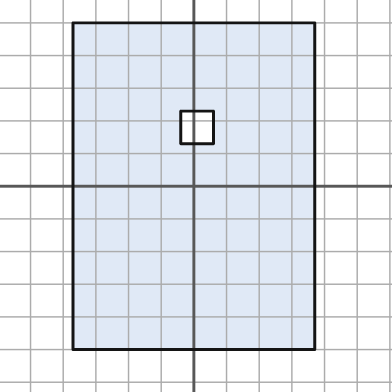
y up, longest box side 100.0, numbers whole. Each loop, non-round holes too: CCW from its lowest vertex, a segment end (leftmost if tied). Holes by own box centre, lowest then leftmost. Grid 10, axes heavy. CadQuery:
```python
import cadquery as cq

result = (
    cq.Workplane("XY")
    .moveTo(-37.0, -50.0)
    .lineTo(37.0, -50.0)
    .lineTo(37.0, 50.0)
    .lineTo(-37.0, 50.0)
    .close()
    .moveTo(-4.0, 13.0)
    .lineTo(6.0, 13.0)
    .lineTo(6.0, 23.0)
    .lineTo(-4.0, 23.0)
    .close()
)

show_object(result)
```